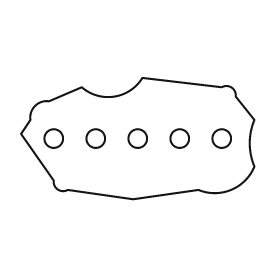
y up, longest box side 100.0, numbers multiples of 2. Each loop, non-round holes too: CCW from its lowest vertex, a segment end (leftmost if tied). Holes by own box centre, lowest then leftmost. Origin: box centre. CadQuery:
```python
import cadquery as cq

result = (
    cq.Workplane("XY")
    .moveTo(-2.0, -26.0)
    .lineTo(26.0, -22.0)
    .threePointArc((40.0, -22.0), (50.0, -12.0))
    .threePointArc((48.0, -2.0), (50.0, 8.0))
    .lineTo(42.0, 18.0)
    .threePointArc((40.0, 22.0), (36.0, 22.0))
    .lineTo(2.0, 26.0)
    .threePointArc((-10.0, 18.0), (-24.0, 22.0))
    .lineTo(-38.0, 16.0)
    .threePointArc((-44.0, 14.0), (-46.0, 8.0))
    .lineTo(-50.0, 2.0)
    .lineTo(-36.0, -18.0)
    .threePointArc((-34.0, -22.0), (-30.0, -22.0))
    .close()
    .moveTo(-36.0, 0.0)
    .circle(4.0)
    .moveTo(-18.0, 0.0)
    .circle(4.0)
    .moveTo(0.0, 0.0)
    .circle(4.0)
    .moveTo(18.0, 0.0)
    .circle(4.0)
    .moveTo(36.0, 0.0)
    .circle(4.0)
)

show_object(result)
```